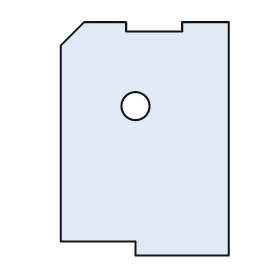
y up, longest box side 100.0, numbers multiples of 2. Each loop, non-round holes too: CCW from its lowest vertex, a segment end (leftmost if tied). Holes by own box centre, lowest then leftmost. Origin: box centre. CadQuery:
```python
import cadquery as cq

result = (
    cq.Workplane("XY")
    .moveTo(-4.0, -50.0)
    .lineTo(36.0, -50.0)
    .lineTo(36.0, 50.0)
    .lineTo(16.0, 50.0)
    .lineTo(16.0, 46.0)
    .lineTo(-8.0, 46.0)
    .lineTo(-8.0, 50.0)
    .lineTo(-26.0, 50.0)
    .lineTo(-36.0, 40.0)
    .lineTo(-36.0, -44.0)
    .lineTo(-4.0, -44.0)
    .close()
    .moveTo(-4.0, 14.0)
    .circle(6.0)
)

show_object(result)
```